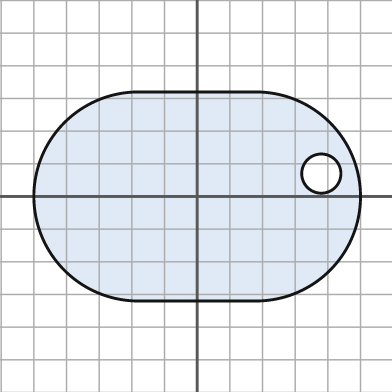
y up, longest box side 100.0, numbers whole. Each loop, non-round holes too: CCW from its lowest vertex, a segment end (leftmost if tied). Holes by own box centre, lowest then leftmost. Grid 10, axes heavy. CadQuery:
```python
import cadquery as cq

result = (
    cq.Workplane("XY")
    .moveTo(-18.0, -32.0)
    .lineTo(18.0, -32.0)
    .threePointArc((50.0, 0.0), (18.0, 32.0))
    .lineTo(-18.0, 32.0)
    .threePointArc((-50.0, 0.0), (-18.0, -32.0))
    .close()
    .moveTo(38.0, 7.0)
    .circle(6.0)
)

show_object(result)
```